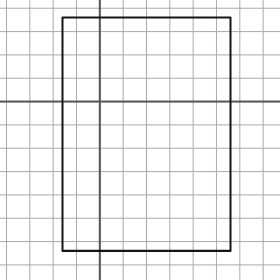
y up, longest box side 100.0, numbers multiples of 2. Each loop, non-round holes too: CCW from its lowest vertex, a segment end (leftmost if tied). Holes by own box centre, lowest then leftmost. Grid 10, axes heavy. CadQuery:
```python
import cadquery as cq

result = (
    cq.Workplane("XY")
    .moveTo(-16.0, -64.0)
    .lineTo(56.0, -64.0)
    .lineTo(56.0, 36.0)
    .lineTo(-16.0, 36.0)
    .close()
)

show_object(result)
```